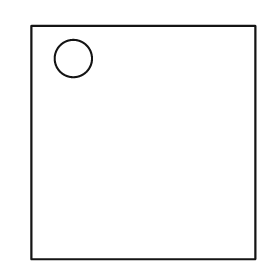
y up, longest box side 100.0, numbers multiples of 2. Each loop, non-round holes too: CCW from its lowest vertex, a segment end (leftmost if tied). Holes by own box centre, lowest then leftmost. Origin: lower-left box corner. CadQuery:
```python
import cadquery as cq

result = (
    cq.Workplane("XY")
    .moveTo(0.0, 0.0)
    .lineTo(96.0, 0.0)
    .lineTo(96.0, 100.0)
    .lineTo(0.0, 100.0)
    .close()
    .moveTo(18.0, 86.0)
    .circle(8.0)
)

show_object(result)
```